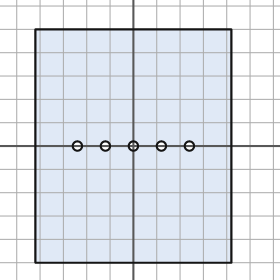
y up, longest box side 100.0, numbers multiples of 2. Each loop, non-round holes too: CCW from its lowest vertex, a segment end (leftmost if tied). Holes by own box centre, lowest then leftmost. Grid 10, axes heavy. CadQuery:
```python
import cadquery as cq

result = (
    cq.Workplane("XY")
    .moveTo(-42.0, -50.0)
    .lineTo(42.0, -50.0)
    .lineTo(42.0, 50.0)
    .lineTo(-42.0, 50.0)
    .close()
    .moveTo(-24.0, 0.0)
    .circle(2.0)
    .moveTo(-12.0, 0.0)
    .circle(2.0)
    .moveTo(0.0, 0.0)
    .circle(2.0)
    .moveTo(12.0, 0.0)
    .circle(2.0)
    .moveTo(24.0, 0.0)
    .circle(2.0)
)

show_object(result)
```